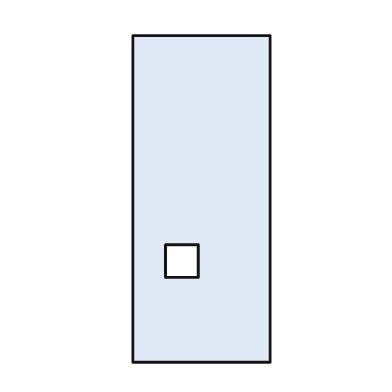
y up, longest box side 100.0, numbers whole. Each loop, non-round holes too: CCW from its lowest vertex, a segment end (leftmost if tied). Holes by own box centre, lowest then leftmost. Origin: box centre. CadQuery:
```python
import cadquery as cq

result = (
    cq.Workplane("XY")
    .moveTo(-21.0, -50.0)
    .lineTo(21.0, -50.0)
    .lineTo(21.0, 50.0)
    .lineTo(-21.0, 50.0)
    .close()
    .moveTo(-11.0, -24.0)
    .lineTo(-1.0, -24.0)
    .lineTo(-1.0, -14.0)
    .lineTo(-11.0, -14.0)
    .close()
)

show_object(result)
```